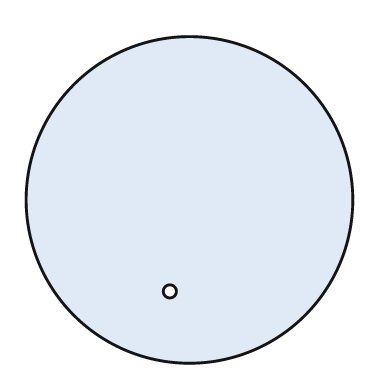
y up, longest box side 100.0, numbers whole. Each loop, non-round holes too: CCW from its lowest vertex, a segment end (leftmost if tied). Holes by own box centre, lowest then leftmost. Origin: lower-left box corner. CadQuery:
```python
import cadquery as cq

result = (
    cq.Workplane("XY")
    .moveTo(50.0, 50.0)
    .circle(50.0)
    .moveTo(44.0, 22.0)
    .circle(2.0)
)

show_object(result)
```